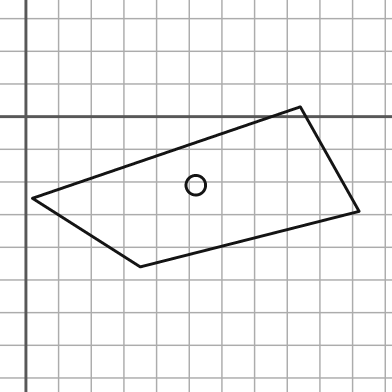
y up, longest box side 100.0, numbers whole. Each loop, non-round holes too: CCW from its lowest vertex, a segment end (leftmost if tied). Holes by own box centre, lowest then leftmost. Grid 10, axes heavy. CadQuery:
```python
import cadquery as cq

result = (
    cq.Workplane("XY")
    .moveTo(35.0, -46.0)
    .lineTo(102.0, -29.0)
    .lineTo(84.0, 3.0)
    .lineTo(2.0, -25.0)
    .close()
    .moveTo(52.0, -21.0)
    .circle(3.0)
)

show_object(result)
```